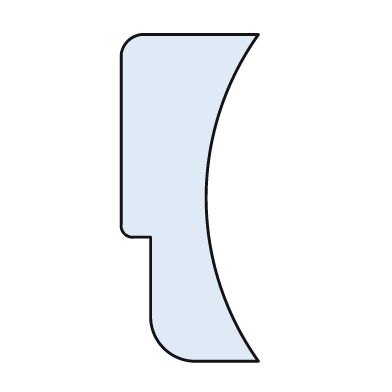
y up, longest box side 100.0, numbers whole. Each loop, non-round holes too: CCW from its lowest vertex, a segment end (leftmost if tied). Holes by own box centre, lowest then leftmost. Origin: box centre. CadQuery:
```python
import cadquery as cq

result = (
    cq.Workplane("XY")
    .moveTo(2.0, -50.0)
    .lineTo(21.0, -50.0)
    .threePointArc((5.0, 0.0), (21.0, 50.0))
    .lineTo(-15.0, 50.0)
    .threePointArc((-19.0, 48.0), (-21.0, 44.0))
    .lineTo(-21.0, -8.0)
    .threePointArc((-20.0, -11.0), (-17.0, -12.0))
    .lineTo(-12.0, -12.0)
    .lineTo(-12.0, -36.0)
    .threePointArc((-8.0, -46.0), (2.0, -50.0))
    .close()
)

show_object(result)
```